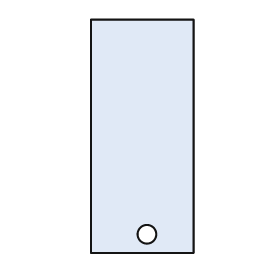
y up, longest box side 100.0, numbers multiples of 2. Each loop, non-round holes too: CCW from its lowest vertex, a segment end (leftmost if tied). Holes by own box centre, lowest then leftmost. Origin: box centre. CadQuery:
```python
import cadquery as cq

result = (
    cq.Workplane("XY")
    .moveTo(-22.0, -50.0)
    .lineTo(22.0, -50.0)
    .lineTo(22.0, 50.0)
    .lineTo(-22.0, 50.0)
    .close()
    .moveTo(2.0, -42.0)
    .circle(4.0)
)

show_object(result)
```